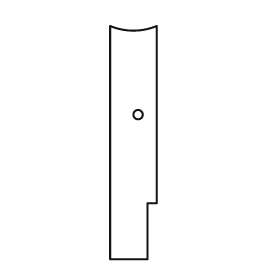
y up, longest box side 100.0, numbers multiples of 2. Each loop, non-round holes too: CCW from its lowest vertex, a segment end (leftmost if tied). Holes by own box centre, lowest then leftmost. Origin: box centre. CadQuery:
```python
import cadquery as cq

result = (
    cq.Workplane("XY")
    .moveTo(-10.0, -50.0)
    .lineTo(6.0, -50.0)
    .lineTo(6.0, -26.0)
    .lineTo(10.0, -26.0)
    .lineTo(10.0, 50.0)
    .threePointArc((0.0, 48.0), (-10.0, 50.0))
    .close()
    .moveTo(2.0, 12.0)
    .circle(2.0)
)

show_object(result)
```